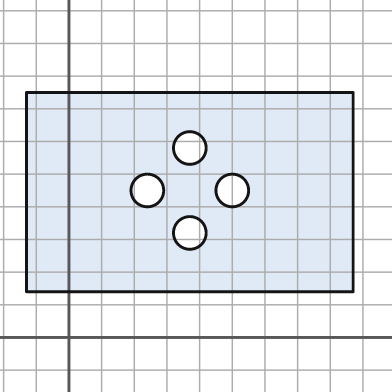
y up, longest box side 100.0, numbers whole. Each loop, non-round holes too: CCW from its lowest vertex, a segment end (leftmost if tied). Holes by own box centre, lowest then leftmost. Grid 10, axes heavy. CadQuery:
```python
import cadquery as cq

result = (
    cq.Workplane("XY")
    .moveTo(-13.0, 14.0)
    .lineTo(87.0, 14.0)
    .lineTo(87.0, 75.0)
    .lineTo(-13.0, 75.0)
    .close()
    .moveTo(37.0, 32.0)
    .circle(5.0)
    .moveTo(24.0, 45.0)
    .circle(5.0)
    .moveTo(50.0, 45.0)
    .circle(5.0)
    .moveTo(37.0, 58.0)
    .circle(5.0)
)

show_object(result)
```